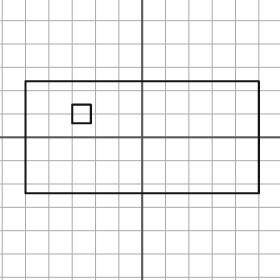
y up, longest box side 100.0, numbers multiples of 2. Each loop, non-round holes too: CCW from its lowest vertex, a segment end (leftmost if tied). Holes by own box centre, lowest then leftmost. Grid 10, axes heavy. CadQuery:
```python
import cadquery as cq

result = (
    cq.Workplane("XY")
    .moveTo(-50.0, -24.0)
    .lineTo(50.0, -24.0)
    .lineTo(50.0, 24.0)
    .lineTo(-50.0, 24.0)
    .close()
    .moveTo(-30.0, 6.0)
    .lineTo(-22.0, 6.0)
    .lineTo(-22.0, 14.0)
    .lineTo(-30.0, 14.0)
    .close()
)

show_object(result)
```